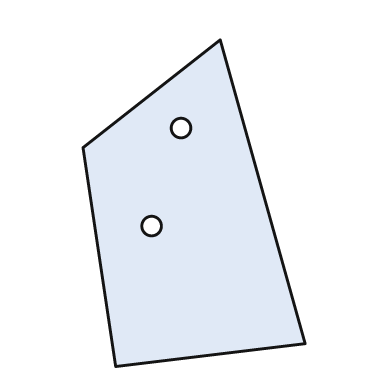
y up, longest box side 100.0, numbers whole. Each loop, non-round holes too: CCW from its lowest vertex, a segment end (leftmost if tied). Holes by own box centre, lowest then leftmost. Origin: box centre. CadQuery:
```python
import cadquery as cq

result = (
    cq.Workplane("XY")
    .moveTo(-24.0, -50.0)
    .lineTo(34.0, -43.0)
    .lineTo(8.0, 50.0)
    .lineTo(-34.0, 17.0)
    .close()
    .moveTo(-13.0, -7.0)
    .circle(3.0)
    .moveTo(-4.0, 23.0)
    .circle(3.0)
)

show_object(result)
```